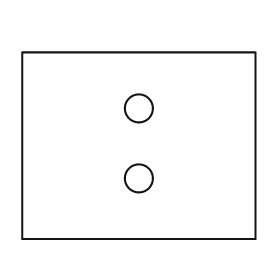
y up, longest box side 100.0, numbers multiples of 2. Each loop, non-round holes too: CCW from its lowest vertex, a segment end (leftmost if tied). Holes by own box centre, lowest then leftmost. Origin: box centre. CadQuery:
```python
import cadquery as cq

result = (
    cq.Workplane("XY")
    .moveTo(-50.0, -40.0)
    .lineTo(50.0, -40.0)
    .lineTo(50.0, 40.0)
    .lineTo(-50.0, 40.0)
    .close()
    .moveTo(0.0, -14.0)
    .circle(6.0)
    .moveTo(0.0, 16.0)
    .circle(6.0)
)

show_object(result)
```